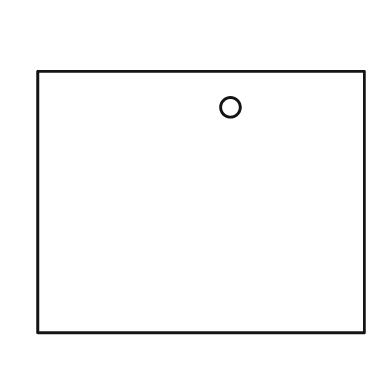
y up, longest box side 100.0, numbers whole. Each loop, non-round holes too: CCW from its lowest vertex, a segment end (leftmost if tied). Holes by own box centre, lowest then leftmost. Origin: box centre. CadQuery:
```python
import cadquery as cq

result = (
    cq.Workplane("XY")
    .moveTo(-50.0, -40.0)
    .lineTo(50.0, -40.0)
    .lineTo(50.0, 40.0)
    .lineTo(-50.0, 40.0)
    .close()
    .moveTo(9.0, 29.0)
    .circle(3.0)
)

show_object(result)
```